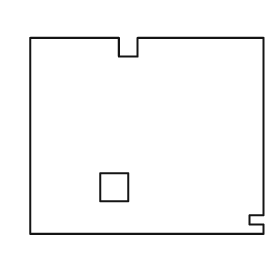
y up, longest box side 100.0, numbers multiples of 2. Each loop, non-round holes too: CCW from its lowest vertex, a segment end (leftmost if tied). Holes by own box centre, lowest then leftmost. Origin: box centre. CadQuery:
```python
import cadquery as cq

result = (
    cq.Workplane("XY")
    .moveTo(-50.0, -42.0)
    .lineTo(50.0, -42.0)
    .lineTo(50.0, -38.0)
    .lineTo(44.0, -38.0)
    .lineTo(44.0, -34.0)
    .lineTo(50.0, -34.0)
    .lineTo(50.0, 42.0)
    .lineTo(-4.0, 42.0)
    .lineTo(-4.0, 34.0)
    .lineTo(-12.0, 34.0)
    .lineTo(-12.0, 42.0)
    .lineTo(-50.0, 42.0)
    .close()
    .moveTo(-20.0, -28.0)
    .lineTo(-8.0, -28.0)
    .lineTo(-8.0, -16.0)
    .lineTo(-20.0, -16.0)
    .close()
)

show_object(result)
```